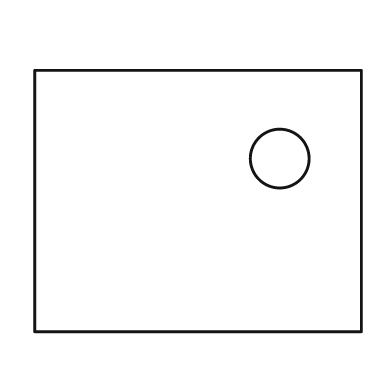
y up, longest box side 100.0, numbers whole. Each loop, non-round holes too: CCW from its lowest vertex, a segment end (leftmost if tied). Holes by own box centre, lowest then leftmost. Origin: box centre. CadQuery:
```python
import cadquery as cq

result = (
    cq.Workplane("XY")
    .moveTo(-50.0, -40.0)
    .lineTo(50.0, -40.0)
    .lineTo(50.0, 40.0)
    .lineTo(-50.0, 40.0)
    .close()
    .moveTo(25.0, 13.0)
    .circle(9.0)
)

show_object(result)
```